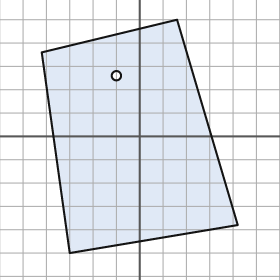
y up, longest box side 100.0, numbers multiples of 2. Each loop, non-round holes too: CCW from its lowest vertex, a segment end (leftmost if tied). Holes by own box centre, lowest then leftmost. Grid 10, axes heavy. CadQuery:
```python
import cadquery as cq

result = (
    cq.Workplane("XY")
    .moveTo(-30.0, -50.0)
    .lineTo(42.0, -38.0)
    .lineTo(16.0, 50.0)
    .lineTo(-42.0, 36.0)
    .close()
    .moveTo(-10.0, 26.0)
    .circle(2.0)
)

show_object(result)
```